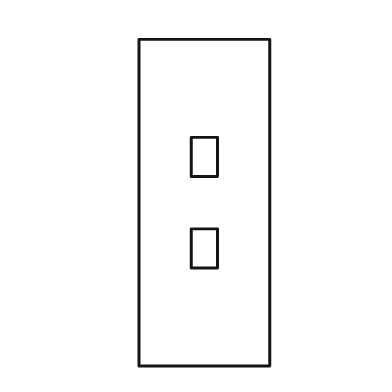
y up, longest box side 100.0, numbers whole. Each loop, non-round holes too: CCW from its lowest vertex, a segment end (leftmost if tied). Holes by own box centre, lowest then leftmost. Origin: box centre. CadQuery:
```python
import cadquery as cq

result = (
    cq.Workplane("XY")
    .moveTo(-20.0, -50.0)
    .lineTo(20.0, -50.0)
    .lineTo(20.0, 50.0)
    .lineTo(-20.0, 50.0)
    .close()
    .moveTo(-4.0, -20.0)
    .lineTo(4.0, -20.0)
    .lineTo(4.0, -8.0)
    .lineTo(-4.0, -8.0)
    .close()
    .moveTo(-4.0, 8.0)
    .lineTo(4.0, 8.0)
    .lineTo(4.0, 20.0)
    .lineTo(-4.0, 20.0)
    .close()
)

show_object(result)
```